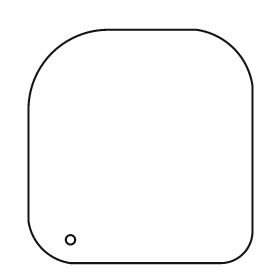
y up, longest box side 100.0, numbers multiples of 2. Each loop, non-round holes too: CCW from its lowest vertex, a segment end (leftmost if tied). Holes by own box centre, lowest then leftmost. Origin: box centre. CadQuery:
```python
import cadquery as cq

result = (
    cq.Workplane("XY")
    .moveTo(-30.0, -50.0)
    .lineTo(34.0, -50.0)
    .threePointArc((44.0, -46.0), (48.0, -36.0))
    .lineTo(48.0, 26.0)
    .threePointArc((40.0, 42.0), (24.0, 50.0))
    .lineTo(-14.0, 50.0)
    .threePointArc((-38.0, 40.0), (-48.0, 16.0))
    .lineTo(-48.0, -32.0)
    .threePointArc((-42.0, -44.0), (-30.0, -50.0))
    .close()
    .moveTo(-30.0, -40.0)
    .circle(2.0)
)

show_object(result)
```